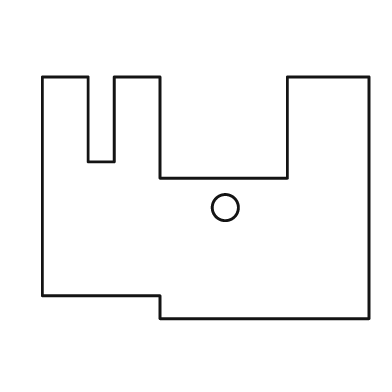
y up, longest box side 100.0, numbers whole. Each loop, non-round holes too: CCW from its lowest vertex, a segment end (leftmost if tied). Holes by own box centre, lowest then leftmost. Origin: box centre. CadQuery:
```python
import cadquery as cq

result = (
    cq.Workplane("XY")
    .moveTo(-14.0, -37.0)
    .lineTo(50.0, -37.0)
    .lineTo(50.0, 37.0)
    .lineTo(25.0, 37.0)
    .lineTo(25.0, 6.0)
    .lineTo(-14.0, 6.0)
    .lineTo(-14.0, 37.0)
    .lineTo(-28.0, 37.0)
    .lineTo(-28.0, 11.0)
    .lineTo(-36.0, 11.0)
    .lineTo(-36.0, 37.0)
    .lineTo(-50.0, 37.0)
    .lineTo(-50.0, -30.0)
    .lineTo(-14.0, -30.0)
    .close()
    .moveTo(6.0, -3.0)
    .circle(4.0)
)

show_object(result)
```